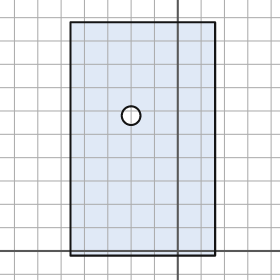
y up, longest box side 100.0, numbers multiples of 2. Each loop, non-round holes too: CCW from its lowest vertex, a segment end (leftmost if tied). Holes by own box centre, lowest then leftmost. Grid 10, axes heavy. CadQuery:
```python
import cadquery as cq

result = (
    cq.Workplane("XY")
    .moveTo(-46.0, -2.0)
    .lineTo(16.0, -2.0)
    .lineTo(16.0, 98.0)
    .lineTo(-46.0, 98.0)
    .close()
    .moveTo(-20.0, 58.0)
    .circle(4.0)
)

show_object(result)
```